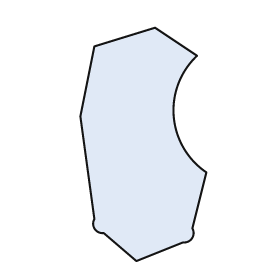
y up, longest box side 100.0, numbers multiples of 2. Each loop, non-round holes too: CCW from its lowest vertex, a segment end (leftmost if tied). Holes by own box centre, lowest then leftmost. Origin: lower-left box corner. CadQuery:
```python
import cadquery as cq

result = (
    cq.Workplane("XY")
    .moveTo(24.0, 0.0)
    .lineTo(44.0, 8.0)
    .threePointArc((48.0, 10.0), (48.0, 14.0))
    .lineTo(54.0, 38.0)
    .threePointArc((40.0, 62.0), (50.0, 88.0))
    .lineTo(32.0, 100.0)
    .lineTo(6.0, 92.0)
    .lineTo(0.0, 62.0)
    .lineTo(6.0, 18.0)
    .threePointArc((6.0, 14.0), (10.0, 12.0))
    .close()
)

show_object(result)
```